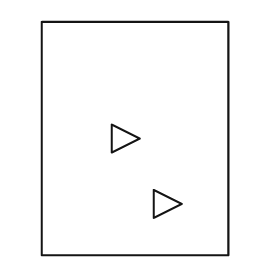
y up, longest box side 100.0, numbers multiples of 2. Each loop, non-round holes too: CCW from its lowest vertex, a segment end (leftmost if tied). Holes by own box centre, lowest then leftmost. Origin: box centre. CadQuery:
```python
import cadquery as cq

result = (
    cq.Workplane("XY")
    .moveTo(-40.0, -50.0)
    .lineTo(40.0, -50.0)
    .lineTo(40.0, 50.0)
    .lineTo(-40.0, 50.0)
    .close()
    .moveTo(8.0, -34.0)
    .lineTo(20.0, -28.0)
    .lineTo(8.0, -22.0)
    .close()
    .moveTo(-10.0, -6.0)
    .lineTo(2.0, 0.0)
    .lineTo(-10.0, 6.0)
    .close()
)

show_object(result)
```